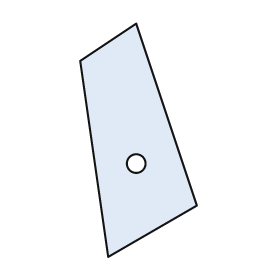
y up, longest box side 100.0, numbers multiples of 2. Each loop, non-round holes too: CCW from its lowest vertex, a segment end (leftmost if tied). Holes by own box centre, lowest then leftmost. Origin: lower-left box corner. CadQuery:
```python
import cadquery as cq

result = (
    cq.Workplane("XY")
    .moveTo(12.0, 0.0)
    .lineTo(50.0, 22.0)
    .lineTo(24.0, 100.0)
    .lineTo(0.0, 84.0)
    .close()
    .moveTo(24.0, 40.0)
    .circle(4.0)
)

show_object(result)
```